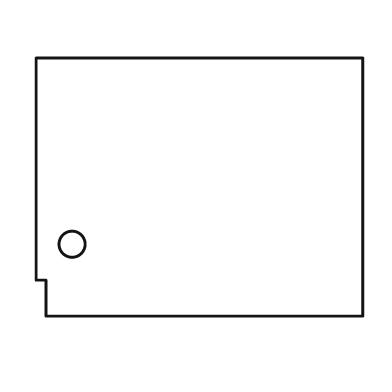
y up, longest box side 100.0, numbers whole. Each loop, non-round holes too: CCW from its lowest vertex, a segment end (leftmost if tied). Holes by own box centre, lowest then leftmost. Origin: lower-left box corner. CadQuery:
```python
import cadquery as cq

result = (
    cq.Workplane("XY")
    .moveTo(3.0, 0.0)
    .lineTo(100.0, 0.0)
    .lineTo(100.0, 79.0)
    .lineTo(0.0, 79.0)
    .lineTo(0.0, 11.0)
    .lineTo(3.0, 11.0)
    .close()
    .moveTo(11.0, 22.0)
    .circle(4.0)
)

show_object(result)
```